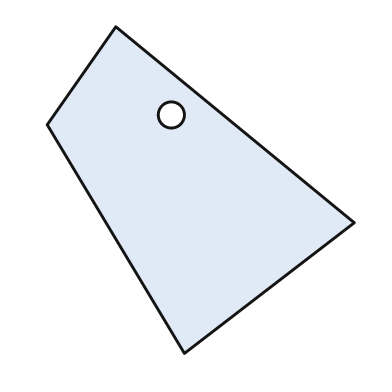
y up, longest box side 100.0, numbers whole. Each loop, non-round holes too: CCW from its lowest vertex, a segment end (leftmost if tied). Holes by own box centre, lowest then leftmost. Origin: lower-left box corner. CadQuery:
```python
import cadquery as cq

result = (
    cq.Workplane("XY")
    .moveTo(42.0, 0.0)
    .lineTo(94.0, 40.0)
    .lineTo(21.0, 100.0)
    .lineTo(0.0, 70.0)
    .close()
    .moveTo(38.0, 73.0)
    .circle(4.0)
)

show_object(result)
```